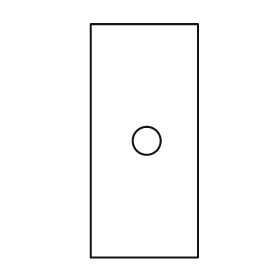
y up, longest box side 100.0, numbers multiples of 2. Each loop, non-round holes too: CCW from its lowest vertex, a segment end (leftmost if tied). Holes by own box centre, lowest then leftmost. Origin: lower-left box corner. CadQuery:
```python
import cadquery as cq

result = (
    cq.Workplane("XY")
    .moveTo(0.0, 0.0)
    .lineTo(46.0, 0.0)
    .lineTo(46.0, 100.0)
    .lineTo(0.0, 100.0)
    .close()
    .moveTo(24.0, 50.0)
    .circle(6.0)
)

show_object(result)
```